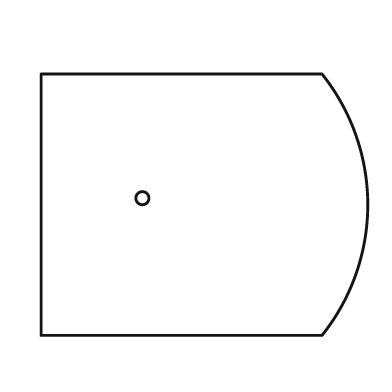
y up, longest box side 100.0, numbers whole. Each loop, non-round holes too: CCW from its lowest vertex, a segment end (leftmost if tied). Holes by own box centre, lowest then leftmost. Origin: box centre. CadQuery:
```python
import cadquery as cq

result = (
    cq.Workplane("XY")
    .moveTo(-50.0, -40.0)
    .lineTo(36.0, -40.0)
    .threePointArc((50.0, 0.0), (36.0, 40.0))
    .lineTo(-50.0, 40.0)
    .close()
    .moveTo(-19.0, 2.0)
    .circle(2.0)
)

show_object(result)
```